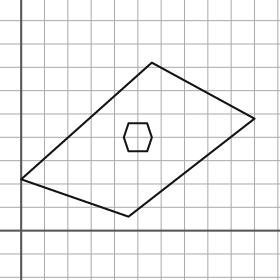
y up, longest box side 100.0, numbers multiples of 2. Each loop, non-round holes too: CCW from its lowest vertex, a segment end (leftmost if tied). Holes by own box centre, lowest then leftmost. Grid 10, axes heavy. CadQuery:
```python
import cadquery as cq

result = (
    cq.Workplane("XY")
    .moveTo(46.0, 6.0)
    .lineTo(100.0, 48.0)
    .lineTo(56.0, 72.0)
    .lineTo(0.0, 22.0)
    .close()
    .moveTo(46.0, 34.0)
    .lineTo(54.0, 34.0)
    .lineTo(56.0, 40.0)
    .lineTo(54.0, 46.0)
    .lineTo(46.0, 46.0)
    .lineTo(44.0, 40.0)
    .close()
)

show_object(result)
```